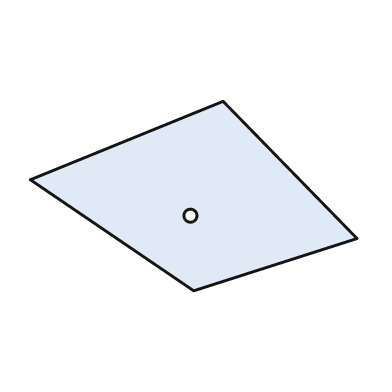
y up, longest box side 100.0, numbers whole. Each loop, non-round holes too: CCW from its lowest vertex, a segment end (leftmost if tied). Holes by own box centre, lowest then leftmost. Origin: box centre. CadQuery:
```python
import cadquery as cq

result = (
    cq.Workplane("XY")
    .moveTo(0.0, -29.0)
    .lineTo(50.0, -13.0)
    .lineTo(9.0, 29.0)
    .lineTo(-50.0, 5.0)
    .close()
    .moveTo(-1.0, -6.0)
    .circle(2.0)
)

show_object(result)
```